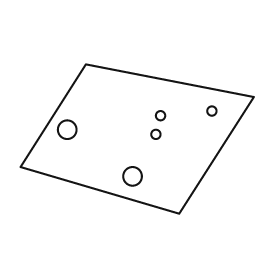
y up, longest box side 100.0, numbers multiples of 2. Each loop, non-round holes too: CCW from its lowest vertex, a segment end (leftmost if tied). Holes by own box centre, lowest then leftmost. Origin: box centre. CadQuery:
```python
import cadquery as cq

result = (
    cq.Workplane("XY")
    .moveTo(18.0, -32.0)
    .lineTo(50.0, 18.0)
    .lineTo(-22.0, 32.0)
    .lineTo(-50.0, -12.0)
    .close()
    .moveTo(-2.0, -16.0)
    .circle(4.0)
    .moveTo(8.0, 2.0)
    .circle(2.0)
    .moveTo(-30.0, 4.0)
    .circle(4.0)
    .moveTo(10.0, 10.0)
    .circle(2.0)
    .moveTo(32.0, 12.0)
    .circle(2.0)
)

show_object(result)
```